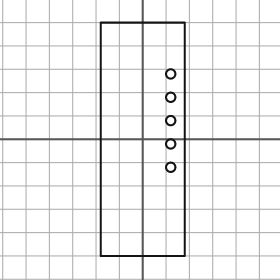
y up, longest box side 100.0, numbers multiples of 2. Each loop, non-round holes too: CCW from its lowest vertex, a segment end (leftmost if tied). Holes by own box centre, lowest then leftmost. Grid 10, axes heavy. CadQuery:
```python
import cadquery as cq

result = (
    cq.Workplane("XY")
    .moveTo(-18.0, -50.0)
    .lineTo(18.0, -50.0)
    .lineTo(18.0, 50.0)
    .lineTo(-18.0, 50.0)
    .close()
    .moveTo(12.0, -12.0)
    .circle(2.0)
    .moveTo(12.0, -2.0)
    .circle(2.0)
    .moveTo(12.0, 8.0)
    .circle(2.0)
    .moveTo(12.0, 18.0)
    .circle(2.0)
    .moveTo(12.0, 28.0)
    .circle(2.0)
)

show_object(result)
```